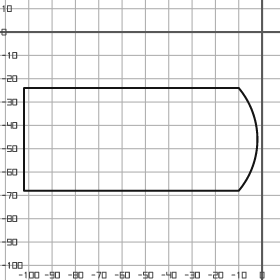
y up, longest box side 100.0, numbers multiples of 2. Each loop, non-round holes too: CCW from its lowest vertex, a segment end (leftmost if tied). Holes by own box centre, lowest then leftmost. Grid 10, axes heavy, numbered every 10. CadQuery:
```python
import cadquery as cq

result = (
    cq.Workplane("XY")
    .moveTo(-102.0, -68.0)
    .lineTo(-10.0, -68.0)
    .threePointArc((-2.0, -46.0), (-10.0, -24.0))
    .lineTo(-102.0, -24.0)
    .close()
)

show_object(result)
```